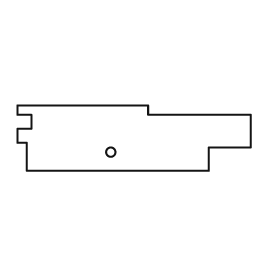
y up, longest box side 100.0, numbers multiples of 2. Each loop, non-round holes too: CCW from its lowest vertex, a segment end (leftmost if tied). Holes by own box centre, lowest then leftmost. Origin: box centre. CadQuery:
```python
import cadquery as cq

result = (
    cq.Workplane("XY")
    .moveTo(-46.0, -14.0)
    .lineTo(32.0, -14.0)
    .lineTo(32.0, -4.0)
    .lineTo(50.0, -4.0)
    .lineTo(50.0, 10.0)
    .lineTo(6.0, 10.0)
    .lineTo(6.0, 14.0)
    .lineTo(-50.0, 14.0)
    .lineTo(-50.0, 10.0)
    .lineTo(-44.0, 10.0)
    .lineTo(-44.0, 4.0)
    .lineTo(-50.0, 4.0)
    .lineTo(-50.0, -2.0)
    .lineTo(-46.0, -2.0)
    .close()
    .moveTo(-10.0, -6.0)
    .circle(2.0)
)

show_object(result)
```